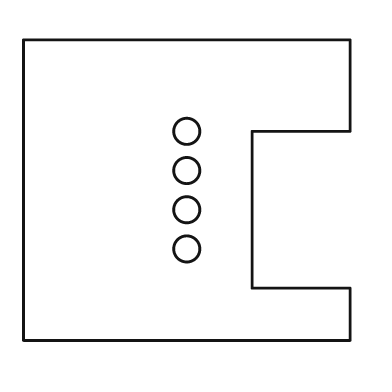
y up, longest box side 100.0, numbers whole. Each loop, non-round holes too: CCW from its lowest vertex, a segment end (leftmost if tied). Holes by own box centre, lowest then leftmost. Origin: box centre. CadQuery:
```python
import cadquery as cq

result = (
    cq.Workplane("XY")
    .moveTo(-50.0, -46.0)
    .lineTo(50.0, -46.0)
    .lineTo(50.0, -30.0)
    .lineTo(20.0, -30.0)
    .lineTo(20.0, 18.0)
    .lineTo(50.0, 18.0)
    .lineTo(50.0, 46.0)
    .lineTo(-50.0, 46.0)
    .close()
    .moveTo(0.0, -18.0)
    .circle(4.0)
    .moveTo(0.0, -6.0)
    .circle(4.0)
    .moveTo(0.0, 6.0)
    .circle(4.0)
    .moveTo(0.0, 18.0)
    .circle(4.0)
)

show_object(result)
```